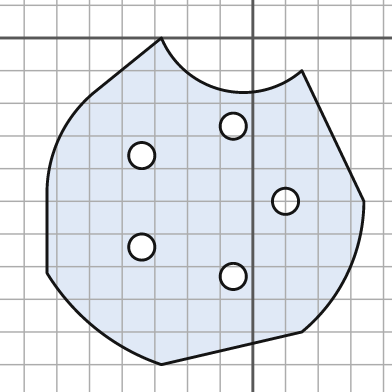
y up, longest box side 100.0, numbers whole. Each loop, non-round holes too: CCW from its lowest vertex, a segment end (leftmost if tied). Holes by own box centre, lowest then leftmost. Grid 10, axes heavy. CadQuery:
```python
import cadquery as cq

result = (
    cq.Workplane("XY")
    .moveTo(-28.0, -100.0)
    .lineTo(15.0, -90.0)
    .threePointArc((29.0, -72.0), (34.0, -50.0))
    .lineTo(15.0, -10.0)
    .threePointArc((-9.0, -16.0), (-28.0, 0.0))
    .lineTo(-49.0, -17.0)
    .threePointArc((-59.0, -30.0), (-63.0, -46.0))
    .lineTo(-63.0, -72.0)
    .threePointArc((-48.0, -89.0), (-28.0, -100.0))
    .close()
    .moveTo(-6.0, -73.0)
    .circle(4.0)
    .moveTo(-34.0, -64.0)
    .circle(4.0)
    .moveTo(10.0, -50.0)
    .circle(4.0)
    .moveTo(-34.0, -36.0)
    .circle(4.0)
    .moveTo(-6.0, -27.0)
    .circle(4.0)
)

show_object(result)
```